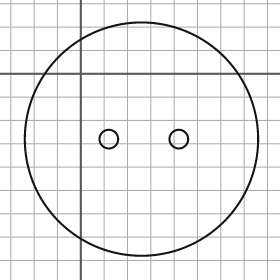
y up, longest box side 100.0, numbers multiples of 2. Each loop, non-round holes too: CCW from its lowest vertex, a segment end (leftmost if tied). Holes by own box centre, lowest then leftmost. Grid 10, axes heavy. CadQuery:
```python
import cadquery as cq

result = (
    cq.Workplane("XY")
    .moveTo(26.0, -28.0)
    .circle(50.0)
    .moveTo(12.0, -28.0)
    .circle(4.0)
    .moveTo(42.0, -28.0)
    .circle(4.0)
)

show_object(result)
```